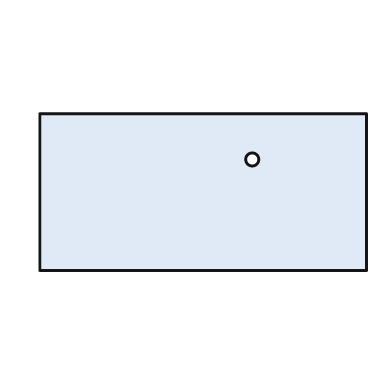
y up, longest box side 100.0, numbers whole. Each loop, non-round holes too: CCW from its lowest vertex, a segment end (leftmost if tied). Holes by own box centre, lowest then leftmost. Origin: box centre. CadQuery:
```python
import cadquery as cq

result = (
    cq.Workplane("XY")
    .moveTo(-50.0, -24.0)
    .lineTo(50.0, -24.0)
    .lineTo(50.0, 24.0)
    .lineTo(-50.0, 24.0)
    .close()
    .moveTo(15.0, 10.0)
    .circle(2.0)
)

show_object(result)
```